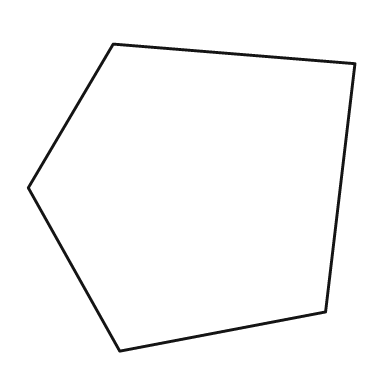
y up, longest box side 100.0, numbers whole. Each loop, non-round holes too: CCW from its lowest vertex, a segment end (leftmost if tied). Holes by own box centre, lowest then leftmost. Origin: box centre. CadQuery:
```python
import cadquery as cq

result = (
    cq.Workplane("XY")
    .moveTo(-22.0, -47.0)
    .lineTo(41.0, -35.0)
    .lineTo(50.0, 41.0)
    .lineTo(-24.0, 47.0)
    .lineTo(-50.0, 3.0)
    .close()
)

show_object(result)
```